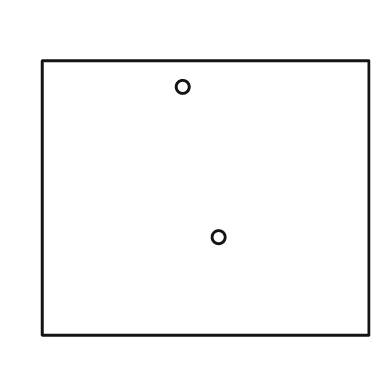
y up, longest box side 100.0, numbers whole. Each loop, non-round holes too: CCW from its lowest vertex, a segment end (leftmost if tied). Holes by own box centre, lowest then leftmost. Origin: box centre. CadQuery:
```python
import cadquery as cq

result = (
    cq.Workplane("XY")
    .moveTo(-50.0, -42.0)
    .lineTo(50.0, -42.0)
    .lineTo(50.0, 42.0)
    .lineTo(-50.0, 42.0)
    .close()
    .moveTo(4.0, -12.0)
    .circle(2.0)
    .moveTo(-7.0, 34.0)
    .circle(2.0)
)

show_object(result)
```